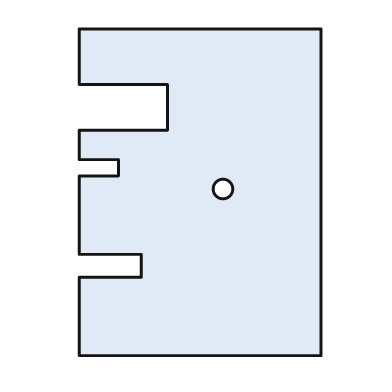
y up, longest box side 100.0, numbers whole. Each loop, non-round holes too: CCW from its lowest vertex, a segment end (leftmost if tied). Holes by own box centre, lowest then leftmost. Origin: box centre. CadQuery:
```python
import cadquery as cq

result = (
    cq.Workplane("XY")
    .moveTo(-37.0, -50.0)
    .lineTo(37.0, -50.0)
    .lineTo(37.0, 50.0)
    .lineTo(-37.0, 50.0)
    .lineTo(-37.0, 33.0)
    .lineTo(-10.0, 33.0)
    .lineTo(-10.0, 19.0)
    .lineTo(-37.0, 19.0)
    .lineTo(-37.0, 10.0)
    .lineTo(-25.0, 10.0)
    .lineTo(-25.0, 5.0)
    .lineTo(-37.0, 5.0)
    .lineTo(-37.0, -19.0)
    .lineTo(-18.0, -19.0)
    .lineTo(-18.0, -26.0)
    .lineTo(-37.0, -26.0)
    .close()
    .moveTo(7.0, 1.0)
    .circle(3.0)
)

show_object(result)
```